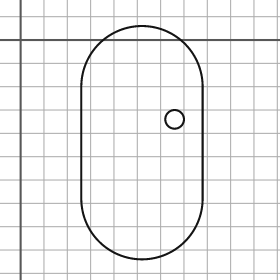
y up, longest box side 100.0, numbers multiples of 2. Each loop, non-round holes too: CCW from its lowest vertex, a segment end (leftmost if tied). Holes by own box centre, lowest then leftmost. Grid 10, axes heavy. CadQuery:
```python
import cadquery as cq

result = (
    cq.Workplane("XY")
    .moveTo(26.0, -68.0)
    .threePointArc((52.0, -94.0), (78.0, -68.0))
    .lineTo(78.0, -20.0)
    .threePointArc((52.0, 6.0), (26.0, -20.0))
    .close()
    .moveTo(66.0, -34.0)
    .circle(4.0)
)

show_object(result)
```